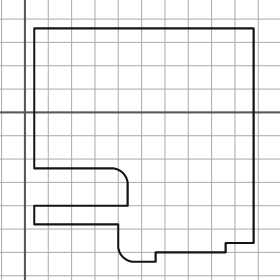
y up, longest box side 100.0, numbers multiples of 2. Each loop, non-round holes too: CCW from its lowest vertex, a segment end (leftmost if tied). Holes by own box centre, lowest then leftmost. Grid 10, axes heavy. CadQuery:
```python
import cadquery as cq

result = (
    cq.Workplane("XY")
    .moveTo(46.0, -64.0)
    .lineTo(56.0, -64.0)
    .lineTo(56.0, -60.0)
    .lineTo(86.0, -60.0)
    .lineTo(86.0, -56.0)
    .lineTo(98.0, -56.0)
    .lineTo(98.0, 36.0)
    .lineTo(4.0, 36.0)
    .lineTo(4.0, -24.0)
    .lineTo(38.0, -24.0)
    .threePointArc((42.0, -26.0), (44.0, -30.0))
    .lineTo(44.0, -40.0)
    .lineTo(4.0, -40.0)
    .lineTo(4.0, -48.0)
    .lineTo(40.0, -48.0)
    .lineTo(40.0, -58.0)
    .threePointArc((42.0, -62.0), (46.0, -64.0))
    .close()
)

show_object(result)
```